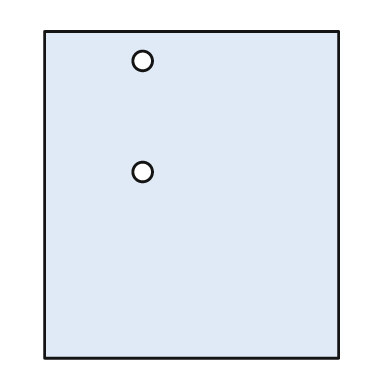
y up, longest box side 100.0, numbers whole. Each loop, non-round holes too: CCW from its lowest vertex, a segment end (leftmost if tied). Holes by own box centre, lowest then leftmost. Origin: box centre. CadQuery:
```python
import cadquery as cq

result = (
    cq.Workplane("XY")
    .moveTo(-45.0, -50.0)
    .lineTo(45.0, -50.0)
    .lineTo(45.0, 50.0)
    .lineTo(-45.0, 50.0)
    .close()
    .moveTo(-15.0, 7.0)
    .circle(3.0)
    .moveTo(-15.0, 41.0)
    .circle(3.0)
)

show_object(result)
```